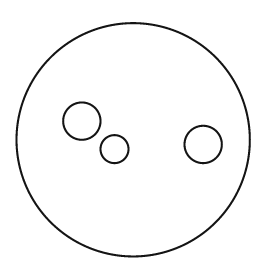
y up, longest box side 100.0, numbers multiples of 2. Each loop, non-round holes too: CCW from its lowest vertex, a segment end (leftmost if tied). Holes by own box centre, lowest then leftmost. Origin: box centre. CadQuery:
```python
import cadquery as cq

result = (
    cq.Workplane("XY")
    .moveTo(0.0, 0.0)
    .circle(50.0)
    .moveTo(-8.0, -4.0)
    .circle(6.0)
    .moveTo(30.0, -2.0)
    .circle(8.0)
    .moveTo(-22.0, 8.0)
    .circle(8.0)
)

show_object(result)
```